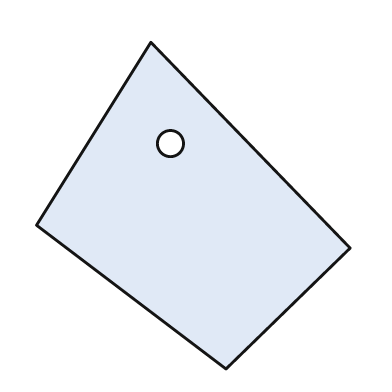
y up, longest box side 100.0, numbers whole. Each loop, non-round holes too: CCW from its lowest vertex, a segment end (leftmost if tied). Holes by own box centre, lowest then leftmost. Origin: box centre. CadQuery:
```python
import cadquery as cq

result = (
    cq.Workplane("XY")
    .moveTo(10.0, -50.0)
    .lineTo(48.0, -13.0)
    .lineTo(-13.0, 50.0)
    .lineTo(-48.0, -6.0)
    .close()
    .moveTo(-7.0, 19.0)
    .circle(4.0)
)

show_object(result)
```